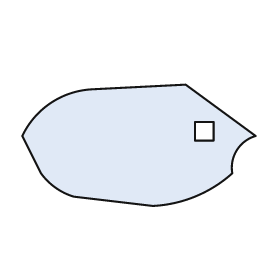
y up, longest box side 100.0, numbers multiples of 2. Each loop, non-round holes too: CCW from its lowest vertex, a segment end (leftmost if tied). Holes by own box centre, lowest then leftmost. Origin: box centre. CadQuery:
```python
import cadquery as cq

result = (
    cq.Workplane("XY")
    .moveTo(6.0, -26.0)
    .threePointArc((24.0, -22.0), (40.0, -12.0))
    .threePointArc((42.0, -2.0), (50.0, 4.0))
    .lineTo(20.0, 26.0)
    .lineTo(-20.0, 24.0)
    .threePointArc((-38.0, 18.0), (-50.0, 4.0))
    .lineTo(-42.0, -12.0)
    .threePointArc((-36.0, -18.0), (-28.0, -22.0))
    .close()
    .moveTo(24.0, 2.0)
    .lineTo(32.0, 2.0)
    .lineTo(32.0, 10.0)
    .lineTo(24.0, 10.0)
    .close()
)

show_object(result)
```